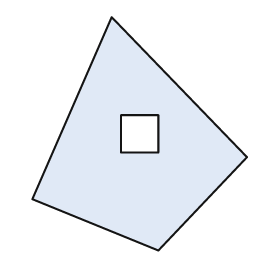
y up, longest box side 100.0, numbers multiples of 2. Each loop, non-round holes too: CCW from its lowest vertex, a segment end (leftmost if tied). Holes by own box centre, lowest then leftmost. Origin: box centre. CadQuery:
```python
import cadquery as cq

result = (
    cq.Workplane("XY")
    .moveTo(8.0, -50.0)
    .lineTo(46.0, -10.0)
    .lineTo(-12.0, 50.0)
    .lineTo(-46.0, -28.0)
    .close()
    .moveTo(-8.0, -8.0)
    .lineTo(8.0, -8.0)
    .lineTo(8.0, 8.0)
    .lineTo(-8.0, 8.0)
    .close()
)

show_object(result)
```